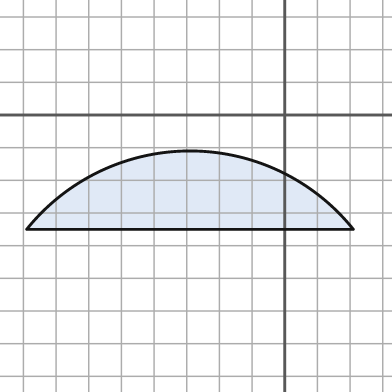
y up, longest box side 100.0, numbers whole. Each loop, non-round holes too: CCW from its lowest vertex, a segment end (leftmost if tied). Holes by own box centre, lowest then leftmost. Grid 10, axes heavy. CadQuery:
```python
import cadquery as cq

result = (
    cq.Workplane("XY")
    .moveTo(-79.0, -35.0)
    .lineTo(21.0, -35.0)
    .threePointArc((-29.0, -11.0), (-79.0, -35.0))
    .close()
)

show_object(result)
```